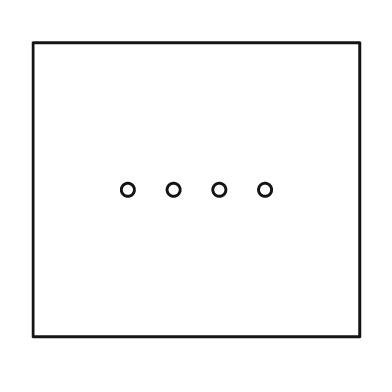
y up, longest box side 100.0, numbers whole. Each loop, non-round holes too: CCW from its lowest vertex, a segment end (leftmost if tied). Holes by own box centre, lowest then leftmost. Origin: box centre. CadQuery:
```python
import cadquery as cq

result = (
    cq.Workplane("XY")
    .moveTo(-50.0, -45.0)
    .lineTo(50.0, -45.0)
    .lineTo(50.0, 45.0)
    .lineTo(-50.0, 45.0)
    .close()
    .moveTo(-21.0, 0.0)
    .circle(2.0)
    .moveTo(-7.0, 0.0)
    .circle(2.0)
    .moveTo(7.0, 0.0)
    .circle(2.0)
    .moveTo(21.0, 0.0)
    .circle(2.0)
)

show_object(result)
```